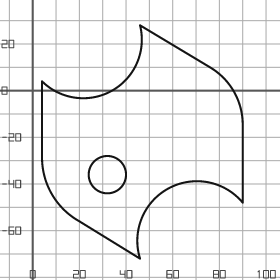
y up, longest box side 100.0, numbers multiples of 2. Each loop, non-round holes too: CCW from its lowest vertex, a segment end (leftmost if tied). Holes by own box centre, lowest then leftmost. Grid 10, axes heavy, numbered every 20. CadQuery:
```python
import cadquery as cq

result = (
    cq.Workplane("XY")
    .moveTo(46.0, -72.0)
    .threePointArc((58.0, -42.0), (90.0, -48.0))
    .lineTo(90.0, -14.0)
    .threePointArc((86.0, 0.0), (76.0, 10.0))
    .lineTo(46.0, 28.0)
    .threePointArc((34.0, 0.0), (4.0, 4.0))
    .lineTo(4.0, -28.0)
    .threePointArc((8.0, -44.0), (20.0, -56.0))
    .close()
    .moveTo(32.0, -36.0)
    .circle(8.0)
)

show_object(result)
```